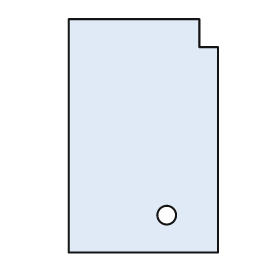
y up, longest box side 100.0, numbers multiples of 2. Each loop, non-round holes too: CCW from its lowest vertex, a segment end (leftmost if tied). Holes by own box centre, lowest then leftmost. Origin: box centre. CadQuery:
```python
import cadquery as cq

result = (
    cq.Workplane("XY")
    .moveTo(-32.0, -50.0)
    .lineTo(32.0, -50.0)
    .lineTo(32.0, 38.0)
    .lineTo(24.0, 38.0)
    .lineTo(24.0, 50.0)
    .lineTo(-32.0, 50.0)
    .close()
    .moveTo(10.0, -34.0)
    .circle(4.0)
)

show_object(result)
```